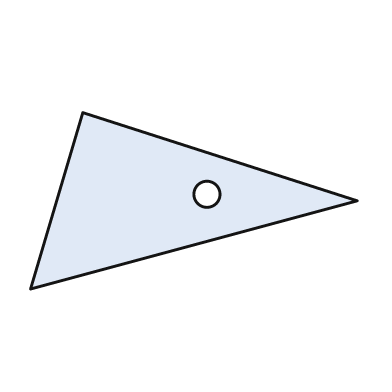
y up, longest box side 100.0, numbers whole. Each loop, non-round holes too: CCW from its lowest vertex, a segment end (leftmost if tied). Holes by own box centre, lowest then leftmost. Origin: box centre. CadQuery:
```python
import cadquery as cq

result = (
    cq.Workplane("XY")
    .moveTo(-50.0, -27.0)
    .lineTo(50.0, 0.0)
    .lineTo(-34.0, 27.0)
    .close()
    .moveTo(4.0, 2.0)
    .circle(4.0)
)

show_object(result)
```